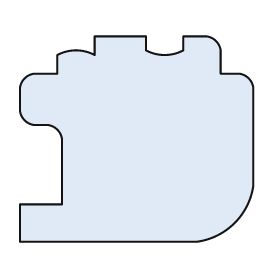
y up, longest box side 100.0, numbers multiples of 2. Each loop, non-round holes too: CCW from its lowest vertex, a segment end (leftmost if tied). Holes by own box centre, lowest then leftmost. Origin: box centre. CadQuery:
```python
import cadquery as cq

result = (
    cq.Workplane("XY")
    .moveTo(-50.0, -44.0)
    .lineTo(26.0, -44.0)
    .threePointArc((42.0, -36.0), (50.0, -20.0))
    .lineTo(50.0, 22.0)
    .threePointArc((48.0, 26.0), (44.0, 28.0))
    .lineTo(36.0, 28.0)
    .lineTo(36.0, 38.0)
    .threePointArc((34.0, 42.0), (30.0, 44.0))
    .lineTo(20.0, 44.0)
    .lineTo(20.0, 38.0)
    .threePointArc((12.0, 36.0), (4.0, 38.0))
    .lineTo(4.0, 44.0)
    .lineTo(-18.0, 44.0)
    .lineTo(-18.0, 36.0)
    .threePointArc((-26.0, 38.0), (-34.0, 36.0))
    .lineTo(-34.0, 28.0)
    .lineTo(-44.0, 28.0)
    .threePointArc((-48.0, 26.0), (-50.0, 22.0))
    .lineTo(-50.0, 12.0)
    .threePointArc((-48.0, 8.0), (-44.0, 6.0))
    .lineTo(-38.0, 6.0)
    .threePointArc((-34.0, 4.0), (-32.0, 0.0))
    .lineTo(-32.0, -28.0)
    .lineTo(-50.0, -28.0)
    .close()
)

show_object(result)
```